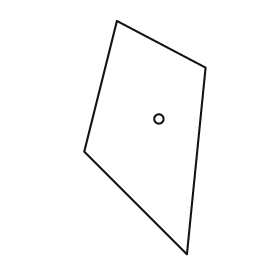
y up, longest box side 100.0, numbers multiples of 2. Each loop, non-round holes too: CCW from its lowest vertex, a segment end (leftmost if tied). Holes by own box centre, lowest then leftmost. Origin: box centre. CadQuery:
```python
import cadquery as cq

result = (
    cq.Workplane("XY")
    .moveTo(18.0, -50.0)
    .lineTo(26.0, 30.0)
    .lineTo(-12.0, 50.0)
    .lineTo(-26.0, -6.0)
    .close()
    .moveTo(6.0, 8.0)
    .circle(2.0)
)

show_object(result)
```